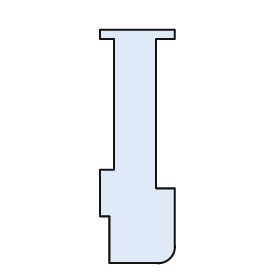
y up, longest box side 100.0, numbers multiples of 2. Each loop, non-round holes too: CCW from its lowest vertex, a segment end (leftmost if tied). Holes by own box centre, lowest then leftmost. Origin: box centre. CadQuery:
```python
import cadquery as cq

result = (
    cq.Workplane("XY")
    .moveTo(-12.0, -50.0)
    .lineTo(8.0, -50.0)
    .threePointArc((14.0, -48.0), (16.0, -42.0))
    .lineTo(16.0, -18.0)
    .lineTo(8.0, -18.0)
    .lineTo(8.0, 46.0)
    .lineTo(16.0, 46.0)
    .lineTo(16.0, 50.0)
    .lineTo(-16.0, 50.0)
    .lineTo(-16.0, 46.0)
    .lineTo(-10.0, 46.0)
    .lineTo(-10.0, -10.0)
    .lineTo(-16.0, -10.0)
    .lineTo(-16.0, -30.0)
    .lineTo(-12.0, -30.0)
    .close()
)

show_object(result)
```